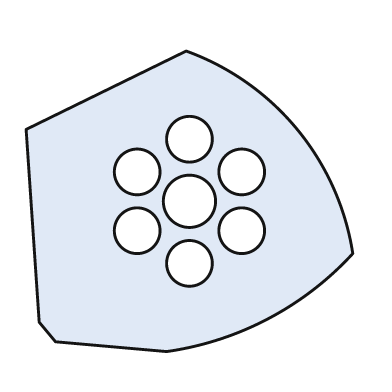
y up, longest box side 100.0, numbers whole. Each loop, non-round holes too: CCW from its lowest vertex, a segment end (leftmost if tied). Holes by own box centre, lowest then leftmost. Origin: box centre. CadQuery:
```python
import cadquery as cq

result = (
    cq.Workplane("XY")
    .moveTo(-7.0, -46.0)
    .threePointArc((24.0, -36.0), (50.0, -16.0))
    .threePointArc((33.0, 22.0), (-1.0, 46.0))
    .lineTo(-50.0, 22.0)
    .lineTo(-46.0, -37.0)
    .lineTo(-41.0, -43.0)
    .close()
    .moveTo(0.0, -19.0)
    .circle(7.0)
    .moveTo(-16.0, -9.0)
    .circle(7.0)
    .moveTo(16.0, -9.0)
    .circle(7.0)
    .moveTo(0.0, 0.0)
    .circle(8.0)
    .moveTo(-16.0, 9.0)
    .circle(7.0)
    .moveTo(16.0, 9.0)
    .circle(7.0)
    .moveTo(0.0, 19.0)
    .circle(7.0)
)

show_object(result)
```